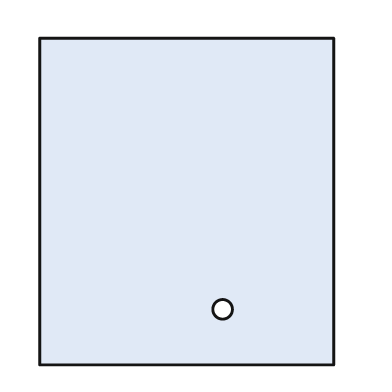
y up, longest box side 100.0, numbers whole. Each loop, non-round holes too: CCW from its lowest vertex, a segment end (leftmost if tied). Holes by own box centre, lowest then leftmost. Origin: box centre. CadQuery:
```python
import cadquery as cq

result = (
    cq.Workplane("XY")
    .moveTo(-45.0, -50.0)
    .lineTo(45.0, -50.0)
    .lineTo(45.0, 50.0)
    .lineTo(-45.0, 50.0)
    .close()
    .moveTo(11.0, -33.0)
    .circle(3.0)
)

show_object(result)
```